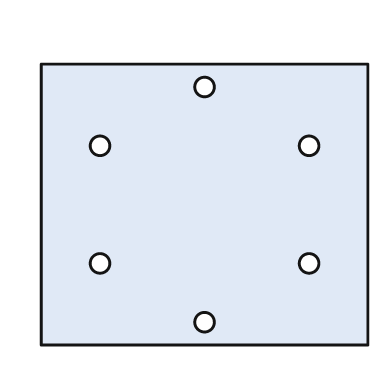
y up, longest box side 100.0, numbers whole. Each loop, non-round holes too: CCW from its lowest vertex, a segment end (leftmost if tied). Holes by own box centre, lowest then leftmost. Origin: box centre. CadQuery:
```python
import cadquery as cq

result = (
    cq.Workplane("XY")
    .moveTo(-50.0, -43.0)
    .lineTo(50.0, -43.0)
    .lineTo(50.0, 43.0)
    .lineTo(-50.0, 43.0)
    .close()
    .moveTo(0.0, -36.0)
    .circle(3.0)
    .moveTo(-32.0, -18.0)
    .circle(3.0)
    .moveTo(32.0, -18.0)
    .circle(3.0)
    .moveTo(-32.0, 18.0)
    .circle(3.0)
    .moveTo(32.0, 18.0)
    .circle(3.0)
    .moveTo(0.0, 36.0)
    .circle(3.0)
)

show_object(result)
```